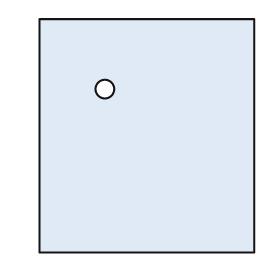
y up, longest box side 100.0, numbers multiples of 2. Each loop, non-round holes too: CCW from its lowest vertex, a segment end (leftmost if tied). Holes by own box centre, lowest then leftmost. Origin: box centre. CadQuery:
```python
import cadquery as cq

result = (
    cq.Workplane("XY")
    .moveTo(-46.0, -50.0)
    .lineTo(46.0, -50.0)
    .lineTo(46.0, 50.0)
    .lineTo(-46.0, 50.0)
    .close()
    .moveTo(-18.0, 20.0)
    .circle(4.0)
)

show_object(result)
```